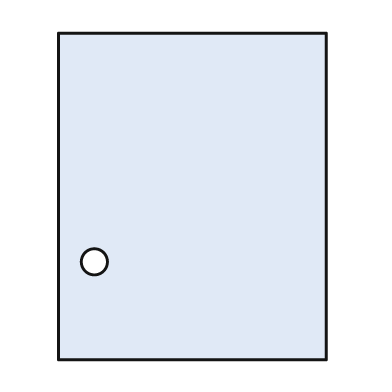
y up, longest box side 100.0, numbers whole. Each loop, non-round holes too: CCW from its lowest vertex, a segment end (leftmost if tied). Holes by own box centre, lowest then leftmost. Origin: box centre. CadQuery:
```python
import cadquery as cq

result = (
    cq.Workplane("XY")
    .moveTo(-41.0, -50.0)
    .lineTo(41.0, -50.0)
    .lineTo(41.0, 50.0)
    .lineTo(-41.0, 50.0)
    .close()
    .moveTo(-30.0, -20.0)
    .circle(4.0)
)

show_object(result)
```